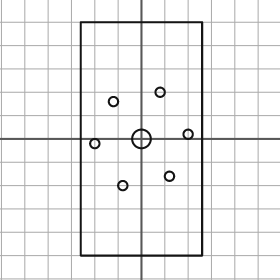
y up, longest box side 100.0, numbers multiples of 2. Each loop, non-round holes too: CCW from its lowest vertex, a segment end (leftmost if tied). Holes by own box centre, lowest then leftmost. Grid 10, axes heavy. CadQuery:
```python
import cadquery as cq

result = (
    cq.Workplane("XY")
    .moveTo(-26.0, -50.0)
    .lineTo(26.0, -50.0)
    .lineTo(26.0, 50.0)
    .lineTo(-26.0, 50.0)
    .close()
    .moveTo(-8.0, -20.0)
    .circle(2.0)
    .moveTo(12.0, -16.0)
    .circle(2.0)
    .moveTo(-20.0, -2.0)
    .circle(2.0)
    .moveTo(0.0, 0.0)
    .circle(4.0)
    .moveTo(20.0, 2.0)
    .circle(2.0)
    .moveTo(-12.0, 16.0)
    .circle(2.0)
    .moveTo(8.0, 20.0)
    .circle(2.0)
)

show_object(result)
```